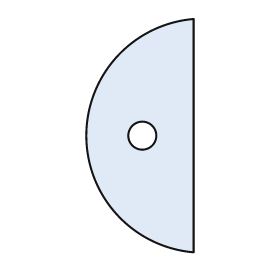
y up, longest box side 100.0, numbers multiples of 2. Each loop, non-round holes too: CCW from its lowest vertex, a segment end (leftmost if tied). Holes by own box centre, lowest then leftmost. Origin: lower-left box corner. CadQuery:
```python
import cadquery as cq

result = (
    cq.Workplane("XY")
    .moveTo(46.0, 0.0)
    .lineTo(46.0, 100.0)
    .threePointArc((0.0, 50.0), (46.0, 0.0))
    .close()
    .moveTo(24.0, 50.0)
    .circle(6.0)
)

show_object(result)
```